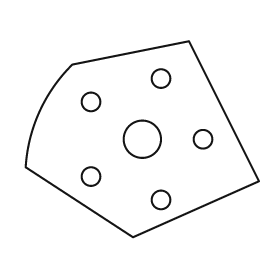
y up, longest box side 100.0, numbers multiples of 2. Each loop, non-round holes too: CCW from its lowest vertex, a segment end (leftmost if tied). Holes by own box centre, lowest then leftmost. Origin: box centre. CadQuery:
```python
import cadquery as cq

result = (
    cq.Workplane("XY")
    .moveTo(-4.0, -42.0)
    .lineTo(50.0, -18.0)
    .lineTo(20.0, 42.0)
    .lineTo(-30.0, 32.0)
    .threePointArc((-44.0, 12.0), (-50.0, -12.0))
    .close()
    .moveTo(8.0, -26.0)
    .circle(4.0)
    .moveTo(-22.0, -16.0)
    .circle(4.0)
    .moveTo(0.0, 0.0)
    .circle(8.0)
    .moveTo(26.0, 0.0)
    .circle(4.0)
    .moveTo(-22.0, 16.0)
    .circle(4.0)
    .moveTo(8.0, 26.0)
    .circle(4.0)
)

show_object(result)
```